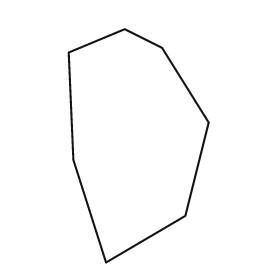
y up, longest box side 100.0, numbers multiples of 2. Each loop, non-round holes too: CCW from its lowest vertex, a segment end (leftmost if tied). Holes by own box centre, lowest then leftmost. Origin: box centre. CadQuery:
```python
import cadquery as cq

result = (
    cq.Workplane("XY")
    .moveTo(-14.0, -50.0)
    .lineTo(20.0, -30.0)
    .lineTo(30.0, 10.0)
    .lineTo(10.0, 42.0)
    .lineTo(-6.0, 50.0)
    .lineTo(-30.0, 40.0)
    .lineTo(-28.0, -6.0)
    .close()
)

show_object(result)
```